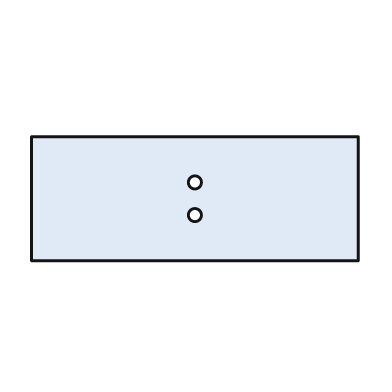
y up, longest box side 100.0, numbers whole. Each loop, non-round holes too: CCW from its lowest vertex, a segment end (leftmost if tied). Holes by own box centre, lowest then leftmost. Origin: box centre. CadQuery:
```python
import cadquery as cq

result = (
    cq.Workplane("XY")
    .moveTo(-50.0, -19.0)
    .lineTo(50.0, -19.0)
    .lineTo(50.0, 19.0)
    .lineTo(-50.0, 19.0)
    .close()
    .moveTo(0.0, -5.0)
    .circle(2.0)
    .moveTo(0.0, 5.0)
    .circle(2.0)
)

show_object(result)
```